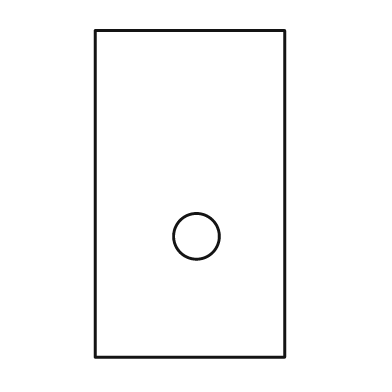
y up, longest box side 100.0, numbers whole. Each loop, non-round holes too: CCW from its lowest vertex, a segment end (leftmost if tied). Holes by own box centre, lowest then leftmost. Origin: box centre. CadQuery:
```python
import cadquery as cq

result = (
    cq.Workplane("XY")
    .moveTo(-29.0, -50.0)
    .lineTo(29.0, -50.0)
    .lineTo(29.0, 50.0)
    .lineTo(-29.0, 50.0)
    .close()
    .moveTo(2.0, -13.0)
    .circle(7.0)
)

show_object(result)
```